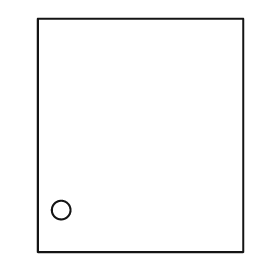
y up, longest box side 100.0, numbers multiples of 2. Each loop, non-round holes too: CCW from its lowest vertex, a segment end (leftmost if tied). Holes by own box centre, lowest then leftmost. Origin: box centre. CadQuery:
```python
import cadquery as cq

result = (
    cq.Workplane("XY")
    .moveTo(-44.0, -50.0)
    .lineTo(44.0, -50.0)
    .lineTo(44.0, 50.0)
    .lineTo(-44.0, 50.0)
    .close()
    .moveTo(-34.0, -32.0)
    .circle(4.0)
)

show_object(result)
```